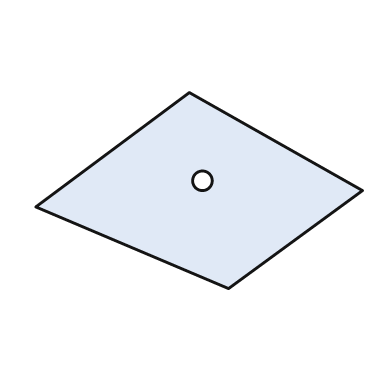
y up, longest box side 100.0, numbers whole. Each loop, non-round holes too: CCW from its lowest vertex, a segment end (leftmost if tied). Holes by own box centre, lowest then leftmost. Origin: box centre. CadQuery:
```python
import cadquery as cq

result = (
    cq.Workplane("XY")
    .moveTo(9.0, -30.0)
    .lineTo(50.0, 0.0)
    .lineTo(-3.0, 30.0)
    .lineTo(-50.0, -5.0)
    .close()
    .moveTo(1.0, 3.0)
    .circle(3.0)
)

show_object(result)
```